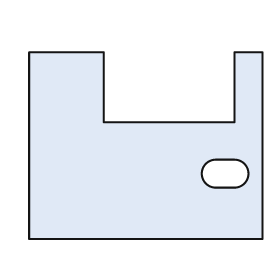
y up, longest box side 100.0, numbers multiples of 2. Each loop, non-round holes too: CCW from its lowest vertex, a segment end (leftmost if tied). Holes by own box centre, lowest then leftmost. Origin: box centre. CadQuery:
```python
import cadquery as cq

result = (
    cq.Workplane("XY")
    .moveTo(-50.0, -40.0)
    .lineTo(50.0, -40.0)
    .lineTo(50.0, 40.0)
    .lineTo(38.0, 40.0)
    .lineTo(38.0, 10.0)
    .lineTo(-18.0, 10.0)
    .lineTo(-18.0, 40.0)
    .lineTo(-50.0, 40.0)
    .close()
    .moveTo(30.0, -18.0)
    .lineTo(38.0, -18.0)
    .threePointArc((44.0, -12.0), (38.0, -6.0))
    .lineTo(30.0, -6.0)
    .threePointArc((24.0, -12.0), (30.0, -18.0))
    .close()
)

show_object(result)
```